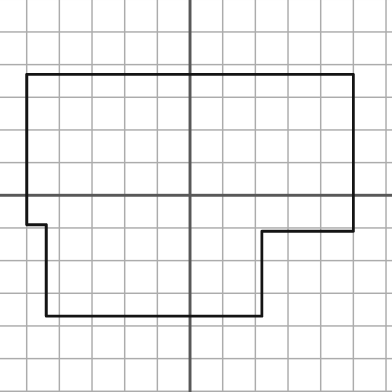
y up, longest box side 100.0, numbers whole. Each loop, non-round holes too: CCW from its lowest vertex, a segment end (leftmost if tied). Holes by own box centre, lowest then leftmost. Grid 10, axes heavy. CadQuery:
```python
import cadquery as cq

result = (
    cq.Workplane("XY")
    .moveTo(-44.0, -37.0)
    .lineTo(22.0, -37.0)
    .lineTo(22.0, -11.0)
    .lineTo(50.0, -11.0)
    .lineTo(50.0, 37.0)
    .lineTo(-50.0, 37.0)
    .lineTo(-50.0, -9.0)
    .lineTo(-44.0, -9.0)
    .close()
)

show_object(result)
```